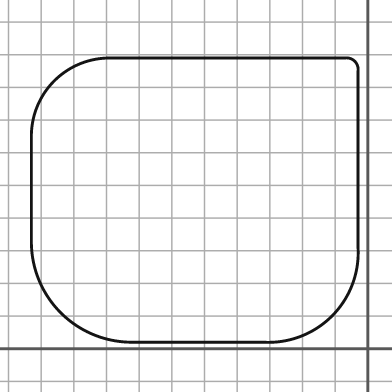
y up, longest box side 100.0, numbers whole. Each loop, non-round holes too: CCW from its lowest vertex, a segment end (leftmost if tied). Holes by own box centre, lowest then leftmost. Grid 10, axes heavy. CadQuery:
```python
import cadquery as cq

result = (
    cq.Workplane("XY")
    .moveTo(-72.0, 2.0)
    .lineTo(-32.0, 2.0)
    .threePointArc((-11.0, 10.0), (-3.0, 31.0))
    .lineTo(-3.0, 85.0)
    .threePointArc((-4.0, 88.0), (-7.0, 89.0))
    .lineTo(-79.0, 89.0)
    .threePointArc((-96.0, 82.0), (-103.0, 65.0))
    .lineTo(-103.0, 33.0)
    .threePointArc((-94.0, 11.0), (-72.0, 2.0))
    .close()
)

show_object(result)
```